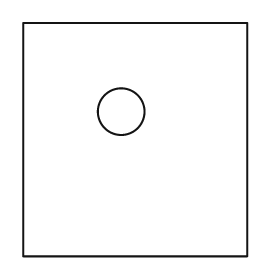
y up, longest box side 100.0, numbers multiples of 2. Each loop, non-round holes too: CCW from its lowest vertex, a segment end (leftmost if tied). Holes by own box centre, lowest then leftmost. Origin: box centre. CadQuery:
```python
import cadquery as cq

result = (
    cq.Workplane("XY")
    .moveTo(-48.0, -50.0)
    .lineTo(48.0, -50.0)
    .lineTo(48.0, 50.0)
    .lineTo(-48.0, 50.0)
    .close()
    .moveTo(-6.0, 12.0)
    .circle(10.0)
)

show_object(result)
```